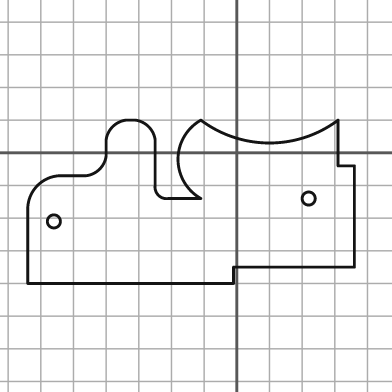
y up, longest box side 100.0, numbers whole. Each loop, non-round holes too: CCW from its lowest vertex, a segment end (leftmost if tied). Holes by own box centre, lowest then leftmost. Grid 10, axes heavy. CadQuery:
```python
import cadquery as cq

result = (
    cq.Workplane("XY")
    .moveTo(-64.0, -40.0)
    .lineTo(-1.0, -40.0)
    .lineTo(-1.0, -35.0)
    .lineTo(36.0, -35.0)
    .lineTo(36.0, -4.0)
    .lineTo(31.0, -4.0)
    .lineTo(31.0, 10.0)
    .threePointArc((10.0, 3.0), (-11.0, 10.0))
    .threePointArc((-18.0, -2.0), (-11.0, -14.0))
    .lineTo(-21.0, -14.0)
    .threePointArc((-24.0, -13.0), (-25.0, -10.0))
    .lineTo(-25.0, 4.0)
    .threePointArc((-27.0, 8.0), (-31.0, 10.0))
    .lineTo(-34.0, 10.0)
    .threePointArc((-38.0, 8.0), (-40.0, 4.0))
    .lineTo(-40.0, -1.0)
    .threePointArc((-42.0, -5.0), (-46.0, -7.0))
    .lineTo(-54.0, -7.0)
    .threePointArc((-61.0, -10.0), (-64.0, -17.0))
    .close()
    .moveTo(-56.0, -21.0)
    .circle(2.0)
    .moveTo(22.0, -14.0)
    .circle(2.0)
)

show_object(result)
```